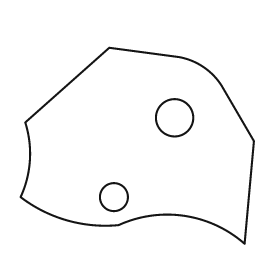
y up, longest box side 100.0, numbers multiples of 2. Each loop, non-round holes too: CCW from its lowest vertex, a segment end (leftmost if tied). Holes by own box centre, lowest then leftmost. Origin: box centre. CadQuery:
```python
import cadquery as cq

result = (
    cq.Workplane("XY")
    .moveTo(46.0, -42.0)
    .lineTo(50.0, 2.0)
    .lineTo(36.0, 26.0)
    .threePointArc((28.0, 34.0), (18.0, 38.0))
    .lineTo(-12.0, 42.0)
    .lineTo(-48.0, 10.0)
    .threePointArc((-46.0, -6.0), (-50.0, -22.0))
    .threePointArc((-30.0, -32.0), (-8.0, -34.0))
    .threePointArc((20.0, -30.0), (46.0, -42.0))
    .close()
    .moveTo(-10.0, -22.0)
    .circle(6.0)
    .moveTo(16.0, 12.0)
    .circle(8.0)
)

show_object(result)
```